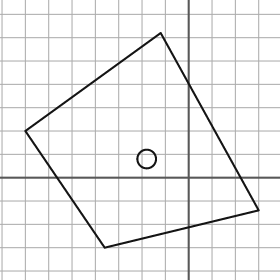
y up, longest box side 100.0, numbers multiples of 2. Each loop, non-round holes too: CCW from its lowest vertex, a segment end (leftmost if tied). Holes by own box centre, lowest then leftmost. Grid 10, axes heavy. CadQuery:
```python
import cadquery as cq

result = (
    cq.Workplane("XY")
    .moveTo(-36.0, -30.0)
    .lineTo(30.0, -14.0)
    .lineTo(-12.0, 62.0)
    .lineTo(-70.0, 20.0)
    .close()
    .moveTo(-18.0, 8.0)
    .circle(4.0)
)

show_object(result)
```